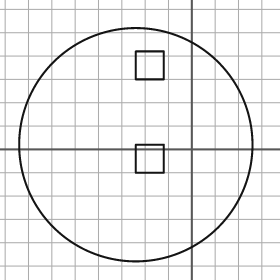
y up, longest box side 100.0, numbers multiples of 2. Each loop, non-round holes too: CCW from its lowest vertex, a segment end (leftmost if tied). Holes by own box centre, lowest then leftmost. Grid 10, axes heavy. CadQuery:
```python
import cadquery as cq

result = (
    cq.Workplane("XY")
    .moveTo(-24.0, 2.0)
    .circle(50.0)
    .moveTo(-24.0, -10.0)
    .lineTo(-12.0, -10.0)
    .lineTo(-12.0, 2.0)
    .lineTo(-24.0, 2.0)
    .close()
    .moveTo(-24.0, 30.0)
    .lineTo(-12.0, 30.0)
    .lineTo(-12.0, 42.0)
    .lineTo(-24.0, 42.0)
    .close()
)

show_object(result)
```